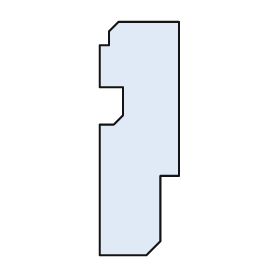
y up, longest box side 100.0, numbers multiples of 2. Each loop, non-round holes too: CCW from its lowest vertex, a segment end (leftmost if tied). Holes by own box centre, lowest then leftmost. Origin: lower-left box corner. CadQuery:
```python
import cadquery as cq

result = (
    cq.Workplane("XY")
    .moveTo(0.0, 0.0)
    .lineTo(20.0, 0.0)
    .lineTo(26.0, 6.0)
    .lineTo(26.0, 34.0)
    .lineTo(34.0, 34.0)
    .lineTo(34.0, 100.0)
    .lineTo(8.0, 100.0)
    .lineTo(4.0, 96.0)
    .lineTo(4.0, 90.0)
    .lineTo(0.0, 90.0)
    .lineTo(0.0, 72.0)
    .lineTo(10.0, 72.0)
    .lineTo(10.0, 60.0)
    .lineTo(6.0, 56.0)
    .lineTo(0.0, 56.0)
    .close()
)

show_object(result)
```